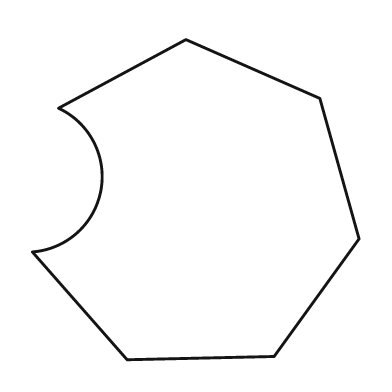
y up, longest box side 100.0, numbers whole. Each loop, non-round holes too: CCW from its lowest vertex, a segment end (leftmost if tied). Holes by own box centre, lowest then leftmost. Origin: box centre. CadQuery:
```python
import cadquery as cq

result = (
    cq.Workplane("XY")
    .moveTo(-21.0, -49.0)
    .lineTo(24.0, -48.0)
    .lineTo(50.0, -12.0)
    .lineTo(38.0, 31.0)
    .lineTo(-3.0, 49.0)
    .lineTo(-42.0, 28.0)
    .threePointArc((-29.0, 3.0), (-50.0, -16.0))
    .close()
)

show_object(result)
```